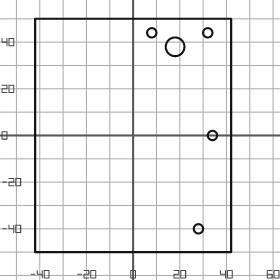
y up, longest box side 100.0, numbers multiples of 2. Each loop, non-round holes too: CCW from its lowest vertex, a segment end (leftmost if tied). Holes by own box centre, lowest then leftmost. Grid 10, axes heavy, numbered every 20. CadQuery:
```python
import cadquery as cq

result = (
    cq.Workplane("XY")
    .moveTo(-42.0, -50.0)
    .lineTo(42.0, -50.0)
    .lineTo(42.0, 50.0)
    .lineTo(-42.0, 50.0)
    .close()
    .moveTo(28.0, -40.0)
    .circle(2.0)
    .moveTo(34.0, 0.0)
    .circle(2.0)
    .moveTo(18.0, 38.0)
    .circle(4.0)
    .moveTo(8.0, 44.0)
    .circle(2.0)
    .moveTo(32.0, 44.0)
    .circle(2.0)
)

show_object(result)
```